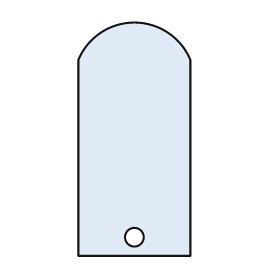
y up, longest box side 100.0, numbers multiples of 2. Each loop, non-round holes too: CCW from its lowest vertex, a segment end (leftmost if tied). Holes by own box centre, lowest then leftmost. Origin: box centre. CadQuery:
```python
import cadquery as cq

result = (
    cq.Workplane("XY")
    .moveTo(-24.0, -50.0)
    .lineTo(24.0, -50.0)
    .lineTo(24.0, 34.0)
    .threePointArc((0.0, 50.0), (-24.0, 34.0))
    .close()
    .moveTo(0.0, -42.0)
    .circle(4.0)
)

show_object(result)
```